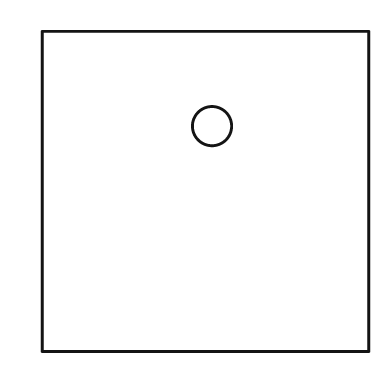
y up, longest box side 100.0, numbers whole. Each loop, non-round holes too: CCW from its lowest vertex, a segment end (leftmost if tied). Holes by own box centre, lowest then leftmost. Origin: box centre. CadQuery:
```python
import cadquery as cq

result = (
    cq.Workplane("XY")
    .moveTo(-50.0, -49.0)
    .lineTo(50.0, -49.0)
    .lineTo(50.0, 49.0)
    .lineTo(-50.0, 49.0)
    .close()
    .moveTo(2.0, 20.0)
    .circle(6.0)
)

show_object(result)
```